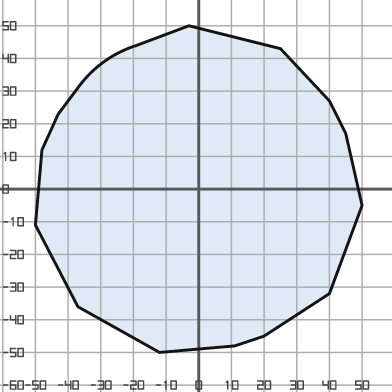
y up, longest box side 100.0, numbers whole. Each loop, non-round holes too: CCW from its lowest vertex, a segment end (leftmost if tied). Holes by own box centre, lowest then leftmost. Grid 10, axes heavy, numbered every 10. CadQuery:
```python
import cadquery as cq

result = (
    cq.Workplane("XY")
    .moveTo(-12.0, -50.0)
    .lineTo(11.0, -48.0)
    .lineTo(20.0, -45.0)
    .lineTo(40.0, -32.0)
    .lineTo(50.0, -5.0)
    .lineTo(45.0, 17.0)
    .lineTo(40.0, 27.0)
    .lineTo(25.0, 43.0)
    .lineTo(-3.0, 50.0)
    .lineTo(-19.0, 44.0)
    .threePointArc((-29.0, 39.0), (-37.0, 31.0))
    .lineTo(-43.0, 23.0)
    .lineTo(-48.0, 12.0)
    .lineTo(-50.0, -11.0)
    .lineTo(-37.0, -36.0)
    .close()
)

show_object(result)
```